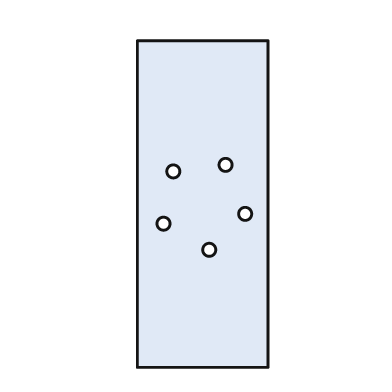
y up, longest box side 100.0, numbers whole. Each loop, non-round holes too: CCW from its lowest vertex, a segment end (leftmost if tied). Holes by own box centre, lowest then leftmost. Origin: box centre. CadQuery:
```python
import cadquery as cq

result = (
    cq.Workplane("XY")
    .moveTo(-20.0, -50.0)
    .lineTo(20.0, -50.0)
    .lineTo(20.0, 50.0)
    .lineTo(-20.0, 50.0)
    .close()
    .moveTo(2.0, -14.0)
    .circle(2.0)
    .moveTo(-12.0, -6.0)
    .circle(2.0)
    .moveTo(13.0, -3.0)
    .circle(2.0)
    .moveTo(-9.0, 10.0)
    .circle(2.0)
    .moveTo(7.0, 12.0)
    .circle(2.0)
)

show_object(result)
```